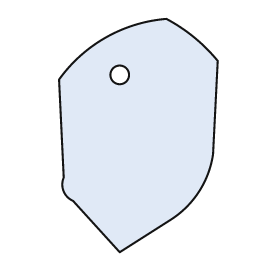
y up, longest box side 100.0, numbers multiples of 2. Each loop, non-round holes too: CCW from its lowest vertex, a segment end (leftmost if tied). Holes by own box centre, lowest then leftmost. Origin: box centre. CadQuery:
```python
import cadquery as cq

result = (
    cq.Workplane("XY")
    .moveTo(-8.0, -50.0)
    .lineTo(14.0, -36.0)
    .threePointArc((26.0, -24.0), (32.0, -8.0))
    .lineTo(34.0, 32.0)
    .threePointArc((24.0, 42.0), (12.0, 50.0))
    .threePointArc((-14.0, 42.0), (-34.0, 24.0))
    .lineTo(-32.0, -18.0)
    .threePointArc((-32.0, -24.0), (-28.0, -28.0))
    .close()
    .moveTo(-8.0, 26.0)
    .circle(4.0)
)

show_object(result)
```